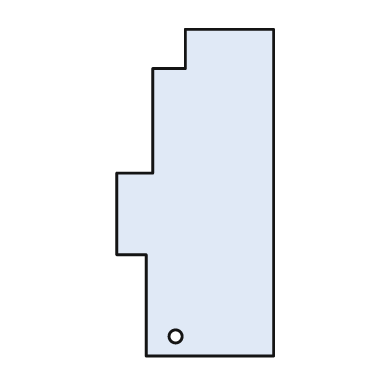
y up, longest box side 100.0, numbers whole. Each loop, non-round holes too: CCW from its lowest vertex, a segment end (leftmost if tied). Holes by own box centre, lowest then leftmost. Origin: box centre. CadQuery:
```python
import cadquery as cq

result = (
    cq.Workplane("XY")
    .moveTo(-15.0, -50.0)
    .lineTo(24.0, -50.0)
    .lineTo(24.0, 50.0)
    .lineTo(-3.0, 50.0)
    .lineTo(-3.0, 38.0)
    .lineTo(-13.0, 38.0)
    .lineTo(-13.0, 6.0)
    .lineTo(-24.0, 6.0)
    .lineTo(-24.0, -19.0)
    .lineTo(-15.0, -19.0)
    .close()
    .moveTo(-6.0, -44.0)
    .circle(2.0)
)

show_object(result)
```